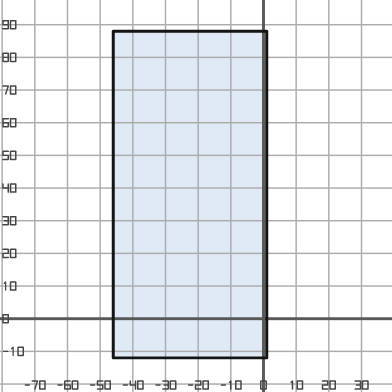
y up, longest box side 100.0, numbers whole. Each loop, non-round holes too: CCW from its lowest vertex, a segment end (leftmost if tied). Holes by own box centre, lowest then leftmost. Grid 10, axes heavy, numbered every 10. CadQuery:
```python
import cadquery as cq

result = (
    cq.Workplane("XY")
    .moveTo(-46.0, -12.0)
    .lineTo(1.0, -12.0)
    .lineTo(1.0, 88.0)
    .lineTo(-46.0, 88.0)
    .close()
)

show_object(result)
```